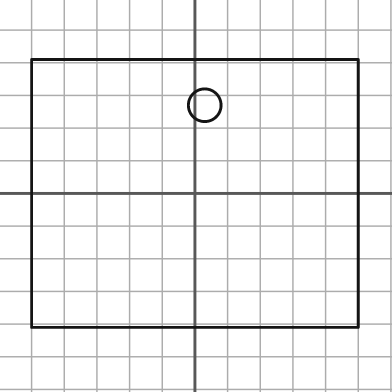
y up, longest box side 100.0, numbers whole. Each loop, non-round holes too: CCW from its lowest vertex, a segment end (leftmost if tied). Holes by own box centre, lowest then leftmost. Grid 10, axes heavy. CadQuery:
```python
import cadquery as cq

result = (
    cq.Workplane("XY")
    .moveTo(-50.0, -41.0)
    .lineTo(50.0, -41.0)
    .lineTo(50.0, 41.0)
    .lineTo(-50.0, 41.0)
    .close()
    .moveTo(3.0, 27.0)
    .circle(5.0)
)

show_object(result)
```